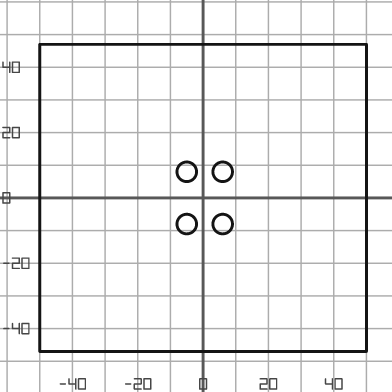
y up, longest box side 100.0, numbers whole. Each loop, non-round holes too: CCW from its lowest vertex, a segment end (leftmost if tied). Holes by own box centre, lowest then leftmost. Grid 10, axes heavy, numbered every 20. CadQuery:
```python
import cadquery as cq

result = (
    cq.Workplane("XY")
    .moveTo(-50.0, -47.0)
    .lineTo(50.0, -47.0)
    .lineTo(50.0, 47.0)
    .lineTo(-50.0, 47.0)
    .close()
    .moveTo(-5.0, -8.0)
    .circle(3.0)
    .moveTo(6.0, -8.0)
    .circle(3.0)
    .moveTo(-5.0, 8.0)
    .circle(3.0)
    .moveTo(6.0, 8.0)
    .circle(3.0)
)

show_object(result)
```